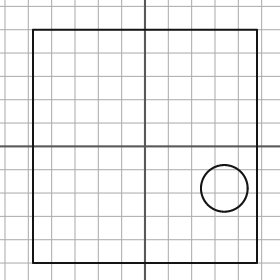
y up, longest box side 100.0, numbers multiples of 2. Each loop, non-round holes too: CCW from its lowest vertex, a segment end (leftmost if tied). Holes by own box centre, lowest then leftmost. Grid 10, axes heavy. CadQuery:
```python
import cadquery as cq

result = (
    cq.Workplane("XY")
    .moveTo(-48.0, -50.0)
    .lineTo(48.0, -50.0)
    .lineTo(48.0, 50.0)
    .lineTo(-48.0, 50.0)
    .close()
    .moveTo(34.0, -18.0)
    .circle(10.0)
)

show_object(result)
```